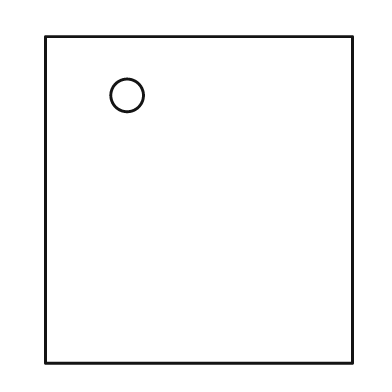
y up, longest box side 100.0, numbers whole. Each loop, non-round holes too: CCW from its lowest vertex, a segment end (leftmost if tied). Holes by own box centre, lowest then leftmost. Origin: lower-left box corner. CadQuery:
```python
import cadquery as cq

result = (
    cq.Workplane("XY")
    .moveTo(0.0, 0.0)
    .lineTo(94.0, 0.0)
    .lineTo(94.0, 100.0)
    .lineTo(0.0, 100.0)
    .close()
    .moveTo(25.0, 82.0)
    .circle(5.0)
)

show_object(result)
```